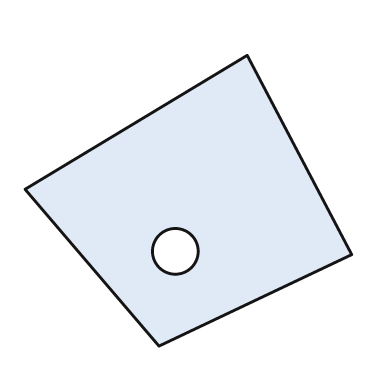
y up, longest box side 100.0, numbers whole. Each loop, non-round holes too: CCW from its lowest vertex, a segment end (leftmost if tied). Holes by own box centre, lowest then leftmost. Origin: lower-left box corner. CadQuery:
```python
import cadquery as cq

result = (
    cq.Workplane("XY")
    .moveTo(41.0, 0.0)
    .lineTo(100.0, 28.0)
    .lineTo(68.0, 89.0)
    .lineTo(0.0, 48.0)
    .close()
    .moveTo(46.0, 29.0)
    .circle(7.0)
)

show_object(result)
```